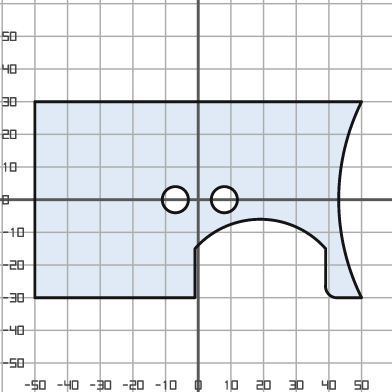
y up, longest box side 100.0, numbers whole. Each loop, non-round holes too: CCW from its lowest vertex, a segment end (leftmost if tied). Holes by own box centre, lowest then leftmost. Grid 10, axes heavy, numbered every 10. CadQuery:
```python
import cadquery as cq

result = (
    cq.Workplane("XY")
    .moveTo(-50.0, -30.0)
    .lineTo(-1.0, -30.0)
    .lineTo(-1.0, -15.0)
    .threePointArc((19.0, -6.0), (39.0, -15.0))
    .lineTo(39.0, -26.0)
    .threePointArc((40.0, -29.0), (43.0, -30.0))
    .lineTo(50.0, -30.0)
    .threePointArc((43.0, 0.0), (50.0, 30.0))
    .lineTo(-50.0, 30.0)
    .close()
    .moveTo(-7.0, 0.0)
    .circle(4.0)
    .moveTo(8.0, 0.0)
    .circle(4.0)
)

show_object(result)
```